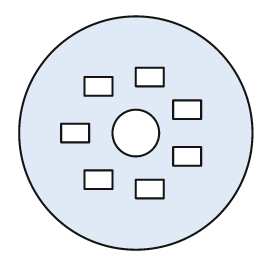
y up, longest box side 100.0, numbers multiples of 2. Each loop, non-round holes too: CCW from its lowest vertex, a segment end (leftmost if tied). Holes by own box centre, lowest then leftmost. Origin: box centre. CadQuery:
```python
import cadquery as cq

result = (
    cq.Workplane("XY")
    .moveTo(0.0, 0.0)
    .circle(50.0)
    .moveTo(0.0, -28.0)
    .lineTo(12.0, -28.0)
    .lineTo(12.0, -20.0)
    .lineTo(0.0, -20.0)
    .close()
    .moveTo(-22.0, -24.0)
    .lineTo(-10.0, -24.0)
    .lineTo(-10.0, -16.0)
    .lineTo(-22.0, -16.0)
    .close()
    .moveTo(16.0, -14.0)
    .lineTo(28.0, -14.0)
    .lineTo(28.0, -6.0)
    .lineTo(16.0, -6.0)
    .close()
    .moveTo(-32.0, -4.0)
    .lineTo(-20.0, -4.0)
    .lineTo(-20.0, 4.0)
    .lineTo(-32.0, 4.0)
    .close()
    .moveTo(0.0, 0.0)
    .circle(10.0)
    .moveTo(16.0, 6.0)
    .lineTo(28.0, 6.0)
    .lineTo(28.0, 14.0)
    .lineTo(16.0, 14.0)
    .close()
    .moveTo(-22.0, 16.0)
    .lineTo(-10.0, 16.0)
    .lineTo(-10.0, 24.0)
    .lineTo(-22.0, 24.0)
    .close()
    .moveTo(0.0, 20.0)
    .lineTo(12.0, 20.0)
    .lineTo(12.0, 28.0)
    .lineTo(0.0, 28.0)
    .close()
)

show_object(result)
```